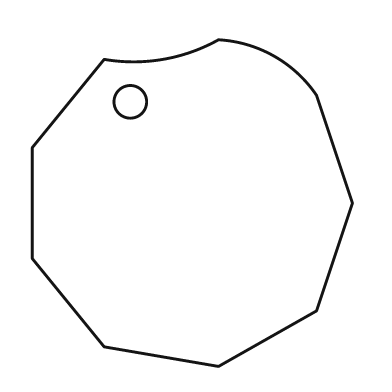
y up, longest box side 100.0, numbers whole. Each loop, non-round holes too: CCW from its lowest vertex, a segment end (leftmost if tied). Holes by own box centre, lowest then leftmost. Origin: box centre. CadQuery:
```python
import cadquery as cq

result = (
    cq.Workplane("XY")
    .moveTo(8.0, -50.0)
    .lineTo(38.0, -33.0)
    .lineTo(49.0, 0.0)
    .lineTo(38.0, 33.0)
    .threePointArc((25.0, 45.0), (8.0, 50.0))
    .threePointArc((-9.0, 44.0), (-27.0, 44.0))
    .lineTo(-49.0, 17.0)
    .lineTo(-49.0, -17.0)
    .lineTo(-27.0, -44.0)
    .close()
    .moveTo(-19.0, 31.0)
    .circle(5.0)
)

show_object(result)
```